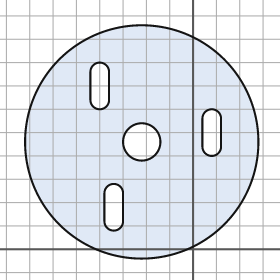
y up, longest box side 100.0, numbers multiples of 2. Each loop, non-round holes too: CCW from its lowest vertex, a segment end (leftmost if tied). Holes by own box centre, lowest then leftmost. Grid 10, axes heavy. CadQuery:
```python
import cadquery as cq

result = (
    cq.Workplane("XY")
    .moveTo(-22.0, 46.0)
    .circle(50.0)
    .moveTo(-38.0, 12.0)
    .threePointArc((-34.0, 8.0), (-30.0, 12.0))
    .lineTo(-30.0, 24.0)
    .threePointArc((-34.0, 28.0), (-38.0, 24.0))
    .close()
    .moveTo(-22.0, 46.0)
    .circle(8.0)
    .moveTo(4.0, 44.0)
    .threePointArc((8.0, 40.0), (12.0, 44.0))
    .lineTo(12.0, 56.0)
    .threePointArc((8.0, 60.0), (4.0, 56.0))
    .close()
    .moveTo(-44.0, 64.0)
    .threePointArc((-40.0, 60.0), (-36.0, 64.0))
    .lineTo(-36.0, 76.0)
    .threePointArc((-40.0, 80.0), (-44.0, 76.0))
    .close()
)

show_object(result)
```